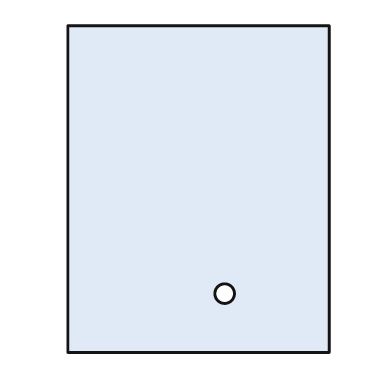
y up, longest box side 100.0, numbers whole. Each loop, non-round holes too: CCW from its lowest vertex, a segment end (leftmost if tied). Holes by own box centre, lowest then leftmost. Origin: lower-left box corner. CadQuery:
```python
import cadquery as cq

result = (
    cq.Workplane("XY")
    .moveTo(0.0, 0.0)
    .lineTo(80.0, 0.0)
    .lineTo(80.0, 100.0)
    .lineTo(0.0, 100.0)
    .close()
    .moveTo(48.0, 18.0)
    .circle(3.0)
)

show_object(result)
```